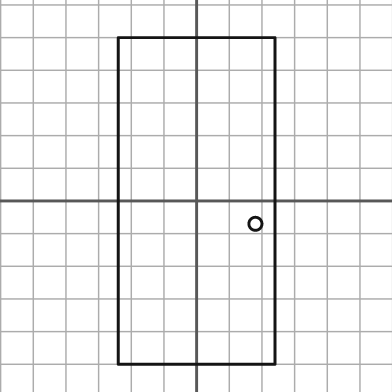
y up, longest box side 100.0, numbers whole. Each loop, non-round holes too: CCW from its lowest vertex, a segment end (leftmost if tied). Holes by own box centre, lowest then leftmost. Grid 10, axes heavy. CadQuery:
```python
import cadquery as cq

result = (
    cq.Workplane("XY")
    .moveTo(-24.0, -50.0)
    .lineTo(24.0, -50.0)
    .lineTo(24.0, 50.0)
    .lineTo(-24.0, 50.0)
    .close()
    .moveTo(18.0, -7.0)
    .circle(2.0)
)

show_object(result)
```